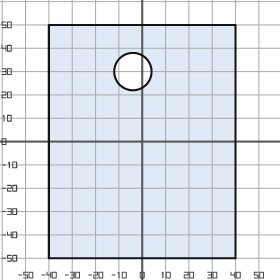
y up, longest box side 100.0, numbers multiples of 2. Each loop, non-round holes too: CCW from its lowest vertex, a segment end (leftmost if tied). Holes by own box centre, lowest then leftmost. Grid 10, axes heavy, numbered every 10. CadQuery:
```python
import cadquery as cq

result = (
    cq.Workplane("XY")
    .moveTo(-40.0, -50.0)
    .lineTo(40.0, -50.0)
    .lineTo(40.0, 50.0)
    .lineTo(-40.0, 50.0)
    .close()
    .moveTo(-4.0, 30.0)
    .circle(8.0)
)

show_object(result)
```